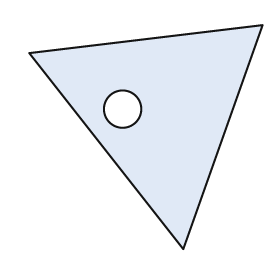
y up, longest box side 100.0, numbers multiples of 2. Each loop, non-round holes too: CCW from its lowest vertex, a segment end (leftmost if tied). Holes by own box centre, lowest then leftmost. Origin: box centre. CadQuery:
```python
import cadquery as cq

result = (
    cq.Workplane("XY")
    .moveTo(16.0, -48.0)
    .lineTo(50.0, 48.0)
    .lineTo(-50.0, 36.0)
    .close()
    .moveTo(-10.0, 12.0)
    .circle(8.0)
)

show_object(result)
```